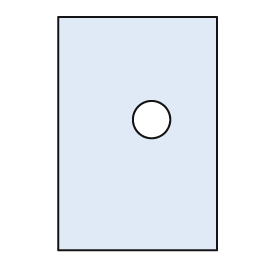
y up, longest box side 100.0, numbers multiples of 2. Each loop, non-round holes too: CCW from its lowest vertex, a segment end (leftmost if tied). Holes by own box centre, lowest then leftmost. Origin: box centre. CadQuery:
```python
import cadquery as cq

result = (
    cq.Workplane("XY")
    .moveTo(-34.0, -50.0)
    .lineTo(34.0, -50.0)
    .lineTo(34.0, 50.0)
    .lineTo(-34.0, 50.0)
    .close()
    .moveTo(6.0, 6.0)
    .circle(8.0)
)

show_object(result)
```